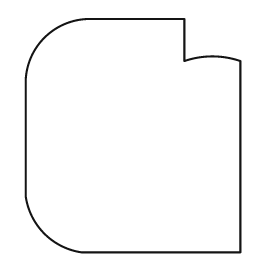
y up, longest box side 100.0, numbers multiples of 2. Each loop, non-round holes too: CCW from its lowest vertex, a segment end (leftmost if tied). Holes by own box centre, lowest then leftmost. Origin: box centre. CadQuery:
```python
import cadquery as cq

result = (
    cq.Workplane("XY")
    .moveTo(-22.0, -50.0)
    .lineTo(46.0, -50.0)
    .lineTo(46.0, 32.0)
    .threePointArc((34.0, 34.0), (22.0, 32.0))
    .lineTo(22.0, 50.0)
    .lineTo(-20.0, 50.0)
    .threePointArc((-38.0, 42.0), (-46.0, 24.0))
    .lineTo(-46.0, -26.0)
    .threePointArc((-38.0, -42.0), (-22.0, -50.0))
    .close()
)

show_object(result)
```